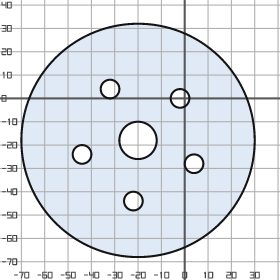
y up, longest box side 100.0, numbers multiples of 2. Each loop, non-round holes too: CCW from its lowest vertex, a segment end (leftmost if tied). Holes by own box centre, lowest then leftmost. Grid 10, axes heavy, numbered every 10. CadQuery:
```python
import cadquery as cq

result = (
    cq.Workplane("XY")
    .moveTo(-20.0, -18.0)
    .circle(50.0)
    .moveTo(-22.0, -44.0)
    .circle(4.0)
    .moveTo(4.0, -28.0)
    .circle(4.0)
    .moveTo(-44.0, -24.0)
    .circle(4.0)
    .moveTo(-20.0, -18.0)
    .circle(8.0)
    .moveTo(-2.0, 0.0)
    .circle(4.0)
    .moveTo(-32.0, 4.0)
    .circle(4.0)
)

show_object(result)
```